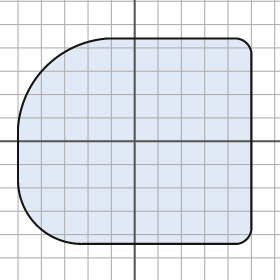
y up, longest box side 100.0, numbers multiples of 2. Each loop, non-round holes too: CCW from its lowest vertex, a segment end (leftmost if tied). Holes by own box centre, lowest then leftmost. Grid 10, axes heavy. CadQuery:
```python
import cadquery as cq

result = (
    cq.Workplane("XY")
    .moveTo(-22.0, -44.0)
    .lineTo(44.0, -44.0)
    .threePointArc((48.0, -42.0), (50.0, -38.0))
    .lineTo(50.0, 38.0)
    .threePointArc((48.0, 42.0), (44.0, 44.0))
    .lineTo(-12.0, 44.0)
    .threePointArc((-38.0, 32.0), (-50.0, 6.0))
    .lineTo(-50.0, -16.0)
    .threePointArc((-42.0, -36.0), (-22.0, -44.0))
    .close()
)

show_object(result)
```